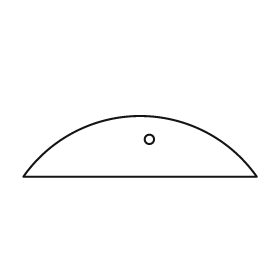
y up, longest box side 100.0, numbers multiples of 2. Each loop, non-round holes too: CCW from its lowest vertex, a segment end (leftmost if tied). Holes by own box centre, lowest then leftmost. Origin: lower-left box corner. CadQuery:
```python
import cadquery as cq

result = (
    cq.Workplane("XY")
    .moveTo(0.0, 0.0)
    .lineTo(100.0, 0.0)
    .threePointArc((50.0, 26.0), (0.0, 0.0))
    .close()
    .moveTo(54.0, 16.0)
    .circle(2.0)
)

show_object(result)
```